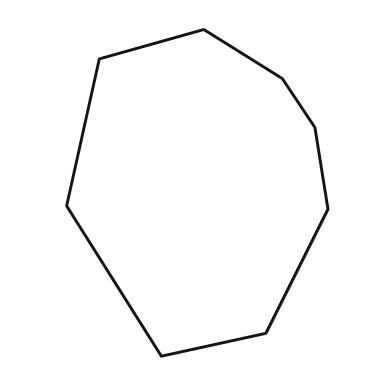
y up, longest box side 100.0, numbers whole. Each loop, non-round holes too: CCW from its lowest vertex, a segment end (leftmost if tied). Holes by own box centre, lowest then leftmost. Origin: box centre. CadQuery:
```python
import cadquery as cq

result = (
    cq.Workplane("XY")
    .moveTo(-11.0, -50.0)
    .lineTo(21.0, -43.0)
    .lineTo(40.0, -5.0)
    .lineTo(36.0, 20.0)
    .lineTo(26.0, 35.0)
    .lineTo(2.0, 50.0)
    .lineTo(-30.0, 41.0)
    .lineTo(-40.0, -4.0)
    .close()
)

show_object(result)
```